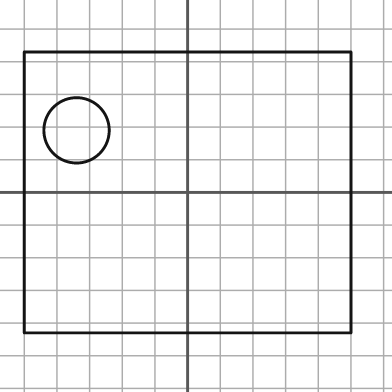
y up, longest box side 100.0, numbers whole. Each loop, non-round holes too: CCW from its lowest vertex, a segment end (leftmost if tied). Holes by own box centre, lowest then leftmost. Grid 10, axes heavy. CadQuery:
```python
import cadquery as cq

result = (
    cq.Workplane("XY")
    .moveTo(-50.0, -43.0)
    .lineTo(50.0, -43.0)
    .lineTo(50.0, 43.0)
    .lineTo(-50.0, 43.0)
    .close()
    .moveTo(-34.0, 19.0)
    .circle(10.0)
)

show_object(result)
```